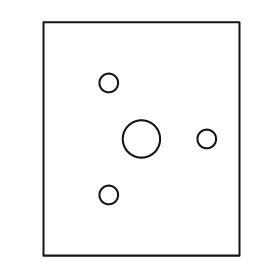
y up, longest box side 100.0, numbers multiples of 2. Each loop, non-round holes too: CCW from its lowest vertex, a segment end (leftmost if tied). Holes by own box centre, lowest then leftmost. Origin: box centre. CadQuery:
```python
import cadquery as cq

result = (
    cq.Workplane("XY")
    .moveTo(-42.0, -50.0)
    .lineTo(42.0, -50.0)
    .lineTo(42.0, 50.0)
    .lineTo(-42.0, 50.0)
    .close()
    .moveTo(-14.0, -24.0)
    .circle(4.0)
    .moveTo(0.0, 0.0)
    .circle(8.0)
    .moveTo(28.0, 0.0)
    .circle(4.0)
    .moveTo(-14.0, 24.0)
    .circle(4.0)
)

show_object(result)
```